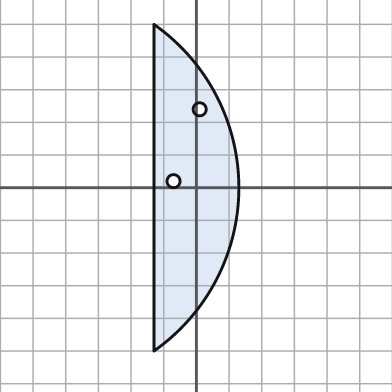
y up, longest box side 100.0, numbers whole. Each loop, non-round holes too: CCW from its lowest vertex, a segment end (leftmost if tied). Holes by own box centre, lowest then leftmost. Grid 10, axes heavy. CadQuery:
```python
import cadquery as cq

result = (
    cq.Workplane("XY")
    .moveTo(-13.0, -50.0)
    .threePointArc((13.0, 0.0), (-13.0, 50.0))
    .close()
    .moveTo(-7.0, 2.0)
    .circle(2.0)
    .moveTo(1.0, 24.0)
    .circle(2.0)
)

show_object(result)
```